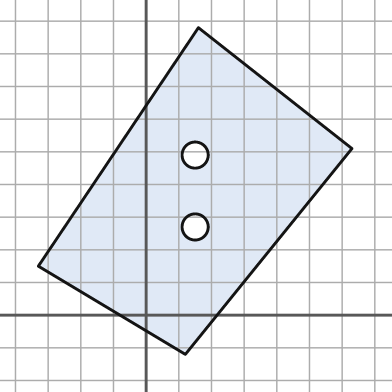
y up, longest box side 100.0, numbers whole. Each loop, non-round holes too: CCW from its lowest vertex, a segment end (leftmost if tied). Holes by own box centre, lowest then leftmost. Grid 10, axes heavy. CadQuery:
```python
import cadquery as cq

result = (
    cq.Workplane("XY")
    .moveTo(12.0, -12.0)
    .lineTo(63.0, 51.0)
    .lineTo(16.0, 88.0)
    .lineTo(-33.0, 15.0)
    .close()
    .moveTo(15.0, 27.0)
    .circle(4.0)
    .moveTo(15.0, 49.0)
    .circle(4.0)
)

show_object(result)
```